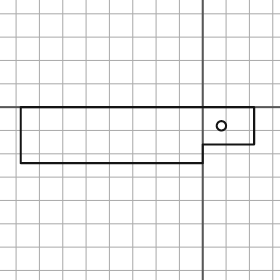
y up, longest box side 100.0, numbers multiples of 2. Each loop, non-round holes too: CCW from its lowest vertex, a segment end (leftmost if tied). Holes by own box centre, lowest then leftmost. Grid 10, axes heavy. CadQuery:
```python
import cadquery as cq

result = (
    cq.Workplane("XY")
    .moveTo(-78.0, -24.0)
    .lineTo(0.0, -24.0)
    .lineTo(0.0, -16.0)
    .lineTo(22.0, -16.0)
    .lineTo(22.0, 0.0)
    .lineTo(-78.0, 0.0)
    .close()
    .moveTo(8.0, -8.0)
    .circle(2.0)
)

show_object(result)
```